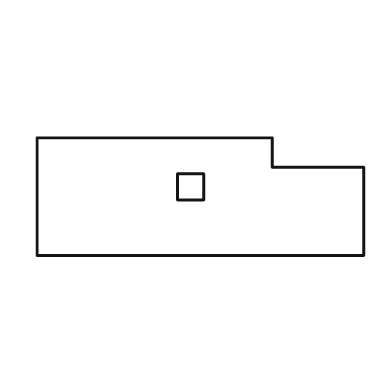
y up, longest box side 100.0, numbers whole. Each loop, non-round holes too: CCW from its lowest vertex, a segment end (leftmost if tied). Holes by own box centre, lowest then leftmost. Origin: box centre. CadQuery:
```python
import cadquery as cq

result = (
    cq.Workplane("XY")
    .moveTo(-50.0, -18.0)
    .lineTo(50.0, -18.0)
    .lineTo(50.0, 9.0)
    .lineTo(22.0, 9.0)
    .lineTo(22.0, 18.0)
    .lineTo(-50.0, 18.0)
    .close()
    .moveTo(-7.0, -1.0)
    .lineTo(1.0, -1.0)
    .lineTo(1.0, 7.0)
    .lineTo(-7.0, 7.0)
    .close()
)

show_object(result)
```